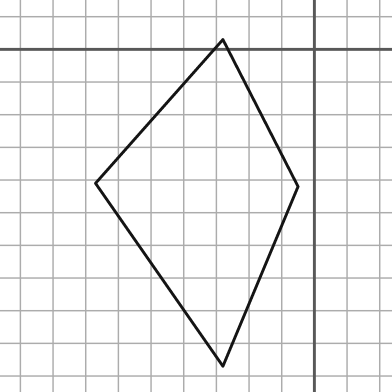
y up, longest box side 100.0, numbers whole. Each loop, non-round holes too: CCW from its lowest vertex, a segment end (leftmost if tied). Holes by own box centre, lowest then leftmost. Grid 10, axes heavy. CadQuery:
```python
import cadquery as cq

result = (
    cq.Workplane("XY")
    .moveTo(-28.0, -97.0)
    .lineTo(-5.0, -42.0)
    .lineTo(-28.0, 3.0)
    .lineTo(-67.0, -41.0)
    .close()
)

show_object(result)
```